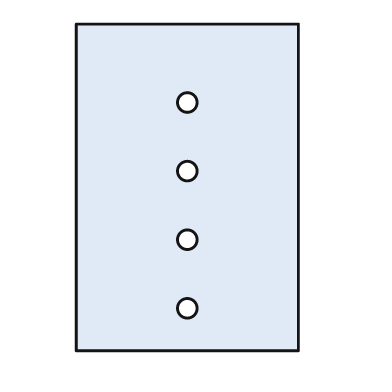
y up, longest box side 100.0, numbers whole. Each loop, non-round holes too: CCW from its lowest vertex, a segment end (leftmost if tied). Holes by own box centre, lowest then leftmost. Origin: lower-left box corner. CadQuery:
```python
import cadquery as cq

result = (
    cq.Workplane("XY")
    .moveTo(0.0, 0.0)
    .lineTo(68.0, 0.0)
    .lineTo(68.0, 100.0)
    .lineTo(0.0, 100.0)
    .close()
    .moveTo(34.0, 13.0)
    .circle(3.0)
    .moveTo(34.0, 34.0)
    .circle(3.0)
    .moveTo(34.0, 55.0)
    .circle(3.0)
    .moveTo(34.0, 76.0)
    .circle(3.0)
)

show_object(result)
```